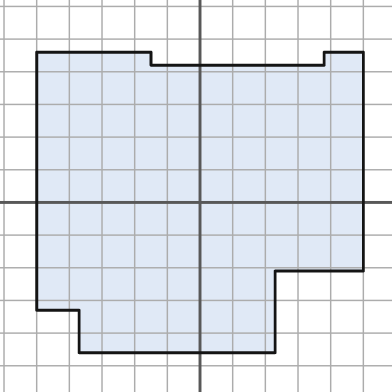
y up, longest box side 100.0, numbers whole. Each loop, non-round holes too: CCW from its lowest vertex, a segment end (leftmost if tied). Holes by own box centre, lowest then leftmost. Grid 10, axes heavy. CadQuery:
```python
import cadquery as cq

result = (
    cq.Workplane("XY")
    .moveTo(-37.0, -46.0)
    .lineTo(23.0, -46.0)
    .lineTo(23.0, -21.0)
    .lineTo(50.0, -21.0)
    .lineTo(50.0, 46.0)
    .lineTo(38.0, 46.0)
    .lineTo(38.0, 42.0)
    .lineTo(-15.0, 42.0)
    .lineTo(-15.0, 46.0)
    .lineTo(-50.0, 46.0)
    .lineTo(-50.0, -33.0)
    .lineTo(-37.0, -33.0)
    .close()
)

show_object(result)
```